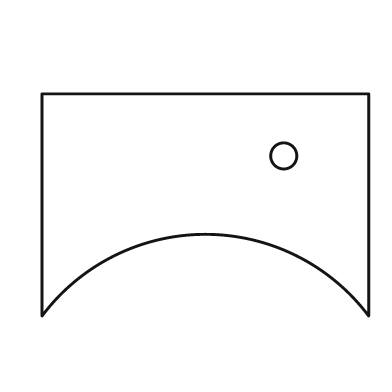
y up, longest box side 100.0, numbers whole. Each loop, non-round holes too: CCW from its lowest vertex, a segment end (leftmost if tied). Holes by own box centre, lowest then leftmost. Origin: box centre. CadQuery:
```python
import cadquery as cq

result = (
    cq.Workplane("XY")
    .moveTo(-50.0, -34.0)
    .threePointArc((0.0, -9.0), (50.0, -34.0))
    .lineTo(50.0, 34.0)
    .lineTo(-50.0, 34.0)
    .close()
    .moveTo(24.0, 15.0)
    .circle(4.0)
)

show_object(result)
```